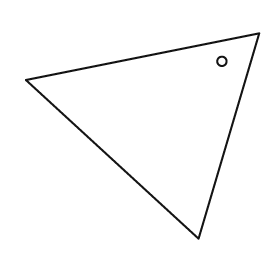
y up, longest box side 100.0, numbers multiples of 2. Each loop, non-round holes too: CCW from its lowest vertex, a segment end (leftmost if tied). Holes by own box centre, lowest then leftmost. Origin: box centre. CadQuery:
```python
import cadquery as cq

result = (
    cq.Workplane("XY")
    .moveTo(24.0, -44.0)
    .lineTo(50.0, 44.0)
    .lineTo(-50.0, 24.0)
    .close()
    .moveTo(34.0, 32.0)
    .circle(2.0)
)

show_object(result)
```